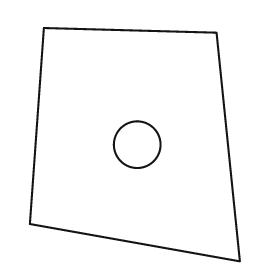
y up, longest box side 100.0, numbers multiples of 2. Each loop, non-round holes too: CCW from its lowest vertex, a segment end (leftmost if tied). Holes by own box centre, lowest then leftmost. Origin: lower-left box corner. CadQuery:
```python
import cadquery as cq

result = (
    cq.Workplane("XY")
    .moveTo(90.0, 0.0)
    .lineTo(80.0, 98.0)
    .lineTo(6.0, 100.0)
    .lineTo(0.0, 16.0)
    .close()
    .moveTo(46.0, 50.0)
    .circle(10.0)
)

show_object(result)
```